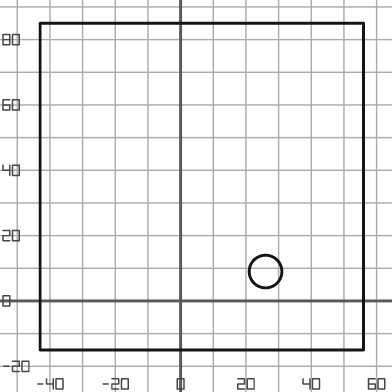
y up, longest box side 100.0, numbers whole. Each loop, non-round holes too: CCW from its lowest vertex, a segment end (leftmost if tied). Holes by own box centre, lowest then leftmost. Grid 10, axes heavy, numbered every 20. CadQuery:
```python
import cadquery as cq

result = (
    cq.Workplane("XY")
    .moveTo(-43.0, -15.0)
    .lineTo(56.0, -15.0)
    .lineTo(56.0, 85.0)
    .lineTo(-43.0, 85.0)
    .close()
    .moveTo(26.0, 9.0)
    .circle(5.0)
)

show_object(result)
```